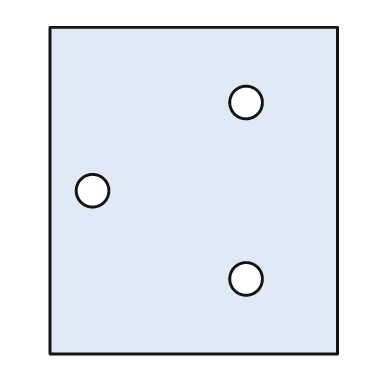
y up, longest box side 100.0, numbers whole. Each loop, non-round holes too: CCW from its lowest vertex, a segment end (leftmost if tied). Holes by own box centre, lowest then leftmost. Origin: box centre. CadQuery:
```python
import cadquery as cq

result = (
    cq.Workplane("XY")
    .moveTo(-44.0, -50.0)
    .lineTo(44.0, -50.0)
    .lineTo(44.0, 50.0)
    .lineTo(-44.0, 50.0)
    .close()
    .moveTo(16.0, -27.0)
    .circle(5.0)
    .moveTo(-31.0, 0.0)
    .circle(5.0)
    .moveTo(16.0, 27.0)
    .circle(5.0)
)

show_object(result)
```